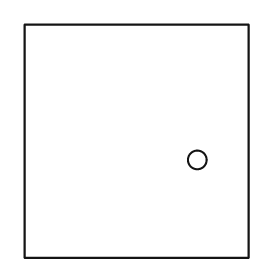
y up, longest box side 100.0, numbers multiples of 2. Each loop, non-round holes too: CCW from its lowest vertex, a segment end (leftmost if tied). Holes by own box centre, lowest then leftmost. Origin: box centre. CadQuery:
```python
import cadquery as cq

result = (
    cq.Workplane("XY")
    .moveTo(-48.0, -50.0)
    .lineTo(48.0, -50.0)
    .lineTo(48.0, 50.0)
    .lineTo(-48.0, 50.0)
    .close()
    .moveTo(26.0, -8.0)
    .circle(4.0)
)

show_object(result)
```